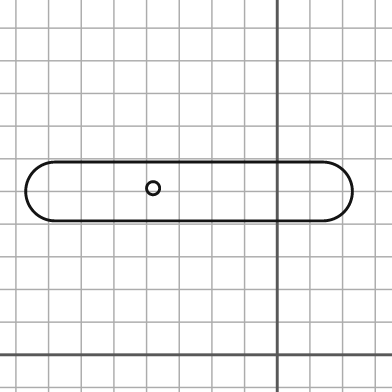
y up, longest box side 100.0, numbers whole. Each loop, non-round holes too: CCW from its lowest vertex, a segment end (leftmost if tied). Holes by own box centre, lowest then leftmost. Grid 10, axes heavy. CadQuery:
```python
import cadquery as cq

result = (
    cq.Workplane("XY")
    .moveTo(-68.0, 41.0)
    .lineTo(14.0, 41.0)
    .threePointArc((23.0, 50.0), (14.0, 59.0))
    .lineTo(-68.0, 59.0)
    .threePointArc((-77.0, 50.0), (-68.0, 41.0))
    .close()
    .moveTo(-38.0, 51.0)
    .circle(2.0)
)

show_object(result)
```